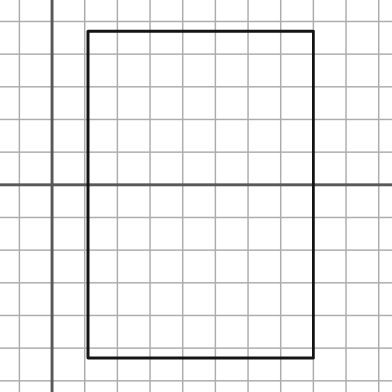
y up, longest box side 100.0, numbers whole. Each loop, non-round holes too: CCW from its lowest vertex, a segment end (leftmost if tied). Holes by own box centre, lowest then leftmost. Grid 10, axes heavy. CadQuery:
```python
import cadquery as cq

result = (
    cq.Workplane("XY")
    .moveTo(11.0, -53.0)
    .lineTo(80.0, -53.0)
    .lineTo(80.0, 47.0)
    .lineTo(11.0, 47.0)
    .close()
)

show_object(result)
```